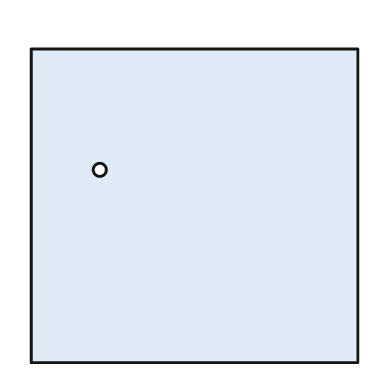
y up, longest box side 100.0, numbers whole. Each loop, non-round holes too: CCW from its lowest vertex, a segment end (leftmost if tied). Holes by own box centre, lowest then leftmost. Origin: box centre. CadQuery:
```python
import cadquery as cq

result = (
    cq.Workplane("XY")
    .moveTo(-50.0, -48.0)
    .lineTo(50.0, -48.0)
    .lineTo(50.0, 48.0)
    .lineTo(-50.0, 48.0)
    .close()
    .moveTo(-29.0, 11.0)
    .circle(2.0)
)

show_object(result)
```